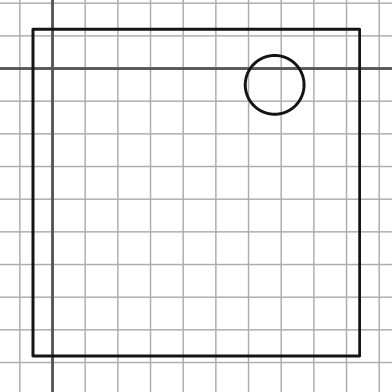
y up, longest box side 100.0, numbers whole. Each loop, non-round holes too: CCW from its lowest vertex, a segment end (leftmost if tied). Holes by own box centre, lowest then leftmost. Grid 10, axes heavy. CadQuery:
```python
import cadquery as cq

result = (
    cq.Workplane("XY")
    .moveTo(-6.0, -88.0)
    .lineTo(94.0, -88.0)
    .lineTo(94.0, 12.0)
    .lineTo(-6.0, 12.0)
    .close()
    .moveTo(68.0, -5.0)
    .circle(9.0)
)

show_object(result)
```